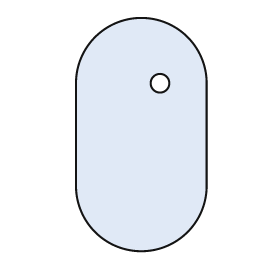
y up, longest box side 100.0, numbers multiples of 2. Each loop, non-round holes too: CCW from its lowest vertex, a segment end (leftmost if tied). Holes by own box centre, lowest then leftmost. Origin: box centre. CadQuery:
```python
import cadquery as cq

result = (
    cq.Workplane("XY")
    .moveTo(-28.0, -22.0)
    .threePointArc((0.0, -50.0), (28.0, -22.0))
    .lineTo(28.0, 22.0)
    .threePointArc((0.0, 50.0), (-28.0, 22.0))
    .close()
    .moveTo(8.0, 22.0)
    .circle(4.0)
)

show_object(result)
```